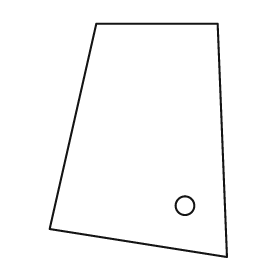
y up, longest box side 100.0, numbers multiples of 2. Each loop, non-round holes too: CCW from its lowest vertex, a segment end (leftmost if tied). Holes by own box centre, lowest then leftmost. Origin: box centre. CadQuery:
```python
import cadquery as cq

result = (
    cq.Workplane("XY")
    .moveTo(38.0, -50.0)
    .lineTo(34.0, 50.0)
    .lineTo(-18.0, 50.0)
    .lineTo(-38.0, -38.0)
    .close()
    .moveTo(20.0, -28.0)
    .circle(4.0)
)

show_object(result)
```